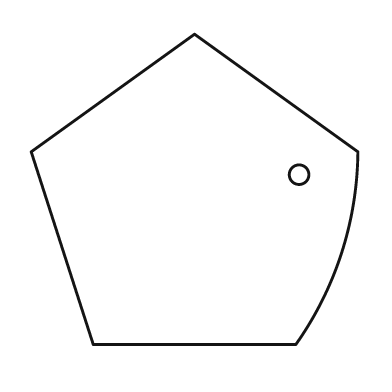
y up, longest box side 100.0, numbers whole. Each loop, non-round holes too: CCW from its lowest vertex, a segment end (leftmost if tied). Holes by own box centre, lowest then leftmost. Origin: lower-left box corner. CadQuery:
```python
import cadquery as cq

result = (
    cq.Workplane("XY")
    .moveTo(19.0, 0.0)
    .lineTo(81.0, 0.0)
    .threePointArc((95.0, 28.0), (100.0, 59.0))
    .lineTo(50.0, 95.0)
    .lineTo(0.0, 59.0)
    .close()
    .moveTo(82.0, 52.0)
    .circle(3.0)
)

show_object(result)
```